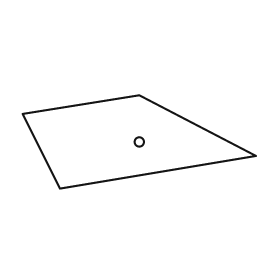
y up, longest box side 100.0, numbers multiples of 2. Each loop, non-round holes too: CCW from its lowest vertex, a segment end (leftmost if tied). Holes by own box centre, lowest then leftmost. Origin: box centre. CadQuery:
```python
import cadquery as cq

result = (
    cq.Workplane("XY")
    .moveTo(-34.0, -20.0)
    .lineTo(50.0, -6.0)
    .lineTo(0.0, 20.0)
    .lineTo(-50.0, 12.0)
    .close()
    .moveTo(0.0, 0.0)
    .circle(2.0)
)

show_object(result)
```